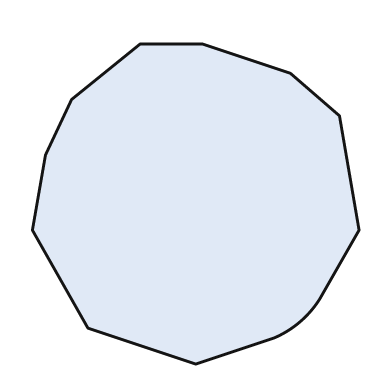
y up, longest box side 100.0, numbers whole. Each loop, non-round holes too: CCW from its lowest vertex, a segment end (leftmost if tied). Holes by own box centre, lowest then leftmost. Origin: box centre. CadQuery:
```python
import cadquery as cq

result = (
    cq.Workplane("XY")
    .moveTo(0.0, -49.0)
    .lineTo(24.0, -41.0)
    .threePointArc((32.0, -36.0), (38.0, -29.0))
    .lineTo(50.0, -8.0)
    .lineTo(44.0, 27.0)
    .lineTo(29.0, 40.0)
    .lineTo(2.0, 49.0)
    .lineTo(-17.0, 49.0)
    .lineTo(-38.0, 32.0)
    .lineTo(-46.0, 15.0)
    .lineTo(-50.0, -8.0)
    .lineTo(-33.0, -38.0)
    .close()
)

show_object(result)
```